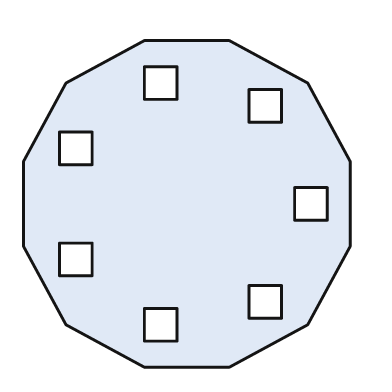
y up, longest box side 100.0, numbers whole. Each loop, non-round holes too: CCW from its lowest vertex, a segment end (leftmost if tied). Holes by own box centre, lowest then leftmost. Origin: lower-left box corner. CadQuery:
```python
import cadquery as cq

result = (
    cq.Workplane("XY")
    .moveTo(37.0, 0.0)
    .lineTo(63.0, 0.0)
    .lineTo(87.0, 13.0)
    .lineTo(100.0, 37.0)
    .lineTo(100.0, 63.0)
    .lineTo(87.0, 87.0)
    .lineTo(63.0, 100.0)
    .lineTo(37.0, 100.0)
    .lineTo(13.0, 87.0)
    .lineTo(0.0, 63.0)
    .lineTo(0.0, 37.0)
    .lineTo(13.0, 13.0)
    .close()
    .moveTo(37.0, 8.0)
    .lineTo(47.0, 8.0)
    .lineTo(47.0, 18.0)
    .lineTo(37.0, 18.0)
    .close()
    .moveTo(69.0, 15.0)
    .lineTo(79.0, 15.0)
    .lineTo(79.0, 25.0)
    .lineTo(69.0, 25.0)
    .close()
    .moveTo(11.0, 28.0)
    .lineTo(21.0, 28.0)
    .lineTo(21.0, 38.0)
    .lineTo(11.0, 38.0)
    .close()
    .moveTo(83.0, 45.0)
    .lineTo(93.0, 45.0)
    .lineTo(93.0, 55.0)
    .lineTo(83.0, 55.0)
    .close()
    .moveTo(11.0, 62.0)
    .lineTo(21.0, 62.0)
    .lineTo(21.0, 72.0)
    .lineTo(11.0, 72.0)
    .close()
    .moveTo(69.0, 75.0)
    .lineTo(79.0, 75.0)
    .lineTo(79.0, 85.0)
    .lineTo(69.0, 85.0)
    .close()
    .moveTo(37.0, 82.0)
    .lineTo(47.0, 82.0)
    .lineTo(47.0, 92.0)
    .lineTo(37.0, 92.0)
    .close()
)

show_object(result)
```